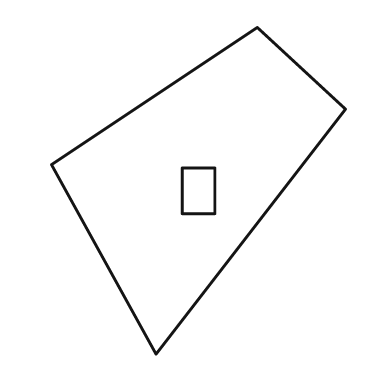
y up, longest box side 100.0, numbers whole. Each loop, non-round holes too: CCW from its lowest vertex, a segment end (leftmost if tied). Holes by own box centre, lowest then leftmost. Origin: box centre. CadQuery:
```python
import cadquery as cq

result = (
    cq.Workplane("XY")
    .moveTo(-13.0, -50.0)
    .lineTo(45.0, 25.0)
    .lineTo(18.0, 50.0)
    .lineTo(-45.0, 8.0)
    .close()
    .moveTo(-5.0, -7.0)
    .lineTo(5.0, -7.0)
    .lineTo(5.0, 7.0)
    .lineTo(-5.0, 7.0)
    .close()
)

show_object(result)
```